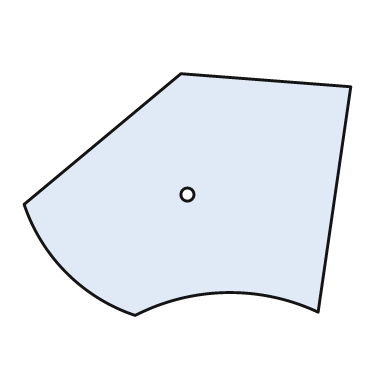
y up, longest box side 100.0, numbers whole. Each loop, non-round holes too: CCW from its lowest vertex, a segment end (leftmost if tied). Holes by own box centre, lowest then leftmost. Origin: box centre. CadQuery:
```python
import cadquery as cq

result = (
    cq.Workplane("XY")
    .moveTo(-16.0, -37.0)
    .threePointArc((12.0, -30.0), (40.0, -36.0))
    .lineTo(50.0, 33.0)
    .lineTo(-2.0, 37.0)
    .lineTo(-50.0, -3.0)
    .threePointArc((-37.0, -24.0), (-16.0, -37.0))
    .close()
    .moveTo(0.0, 0.0)
    .circle(2.0)
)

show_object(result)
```